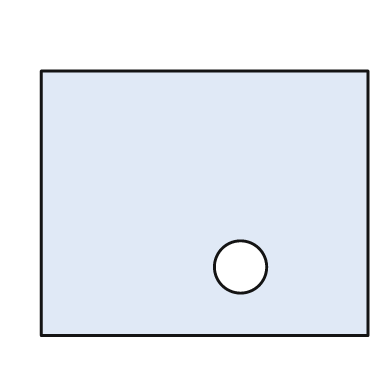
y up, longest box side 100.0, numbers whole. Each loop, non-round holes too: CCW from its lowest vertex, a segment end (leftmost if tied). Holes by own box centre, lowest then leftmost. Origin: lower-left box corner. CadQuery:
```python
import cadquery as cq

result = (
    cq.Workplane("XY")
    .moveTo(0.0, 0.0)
    .lineTo(100.0, 0.0)
    .lineTo(100.0, 81.0)
    .lineTo(0.0, 81.0)
    .close()
    .moveTo(61.0, 21.0)
    .circle(8.0)
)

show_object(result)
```